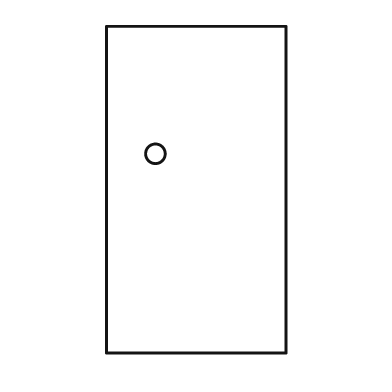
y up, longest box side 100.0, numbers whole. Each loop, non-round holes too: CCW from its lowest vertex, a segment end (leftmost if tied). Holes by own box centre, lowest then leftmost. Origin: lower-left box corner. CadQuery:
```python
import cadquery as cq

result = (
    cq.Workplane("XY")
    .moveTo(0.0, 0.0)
    .lineTo(55.0, 0.0)
    .lineTo(55.0, 100.0)
    .lineTo(0.0, 100.0)
    .close()
    .moveTo(15.0, 61.0)
    .circle(3.0)
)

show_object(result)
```